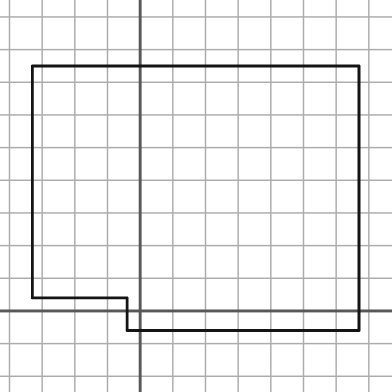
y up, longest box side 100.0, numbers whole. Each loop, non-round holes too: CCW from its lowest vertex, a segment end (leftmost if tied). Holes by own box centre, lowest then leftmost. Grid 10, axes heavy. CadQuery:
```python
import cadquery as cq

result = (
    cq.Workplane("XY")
    .moveTo(-4.0, -6.0)
    .lineTo(67.0, -6.0)
    .lineTo(67.0, 75.0)
    .lineTo(-33.0, 75.0)
    .lineTo(-33.0, 4.0)
    .lineTo(-4.0, 4.0)
    .close()
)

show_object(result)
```